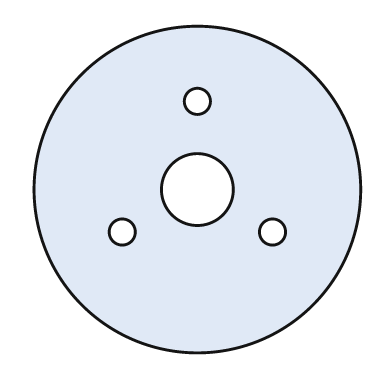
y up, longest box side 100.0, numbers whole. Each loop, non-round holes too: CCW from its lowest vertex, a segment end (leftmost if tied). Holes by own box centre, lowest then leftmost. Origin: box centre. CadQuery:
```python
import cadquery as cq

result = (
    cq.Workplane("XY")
    .moveTo(0.0, 0.0)
    .circle(50.0)
    .moveTo(-23.0, -13.0)
    .circle(4.0)
    .moveTo(23.0, -13.0)
    .circle(4.0)
    .moveTo(0.0, 0.0)
    .circle(11.0)
    .moveTo(0.0, 27.0)
    .circle(4.0)
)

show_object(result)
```